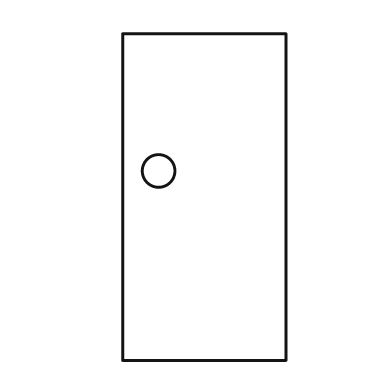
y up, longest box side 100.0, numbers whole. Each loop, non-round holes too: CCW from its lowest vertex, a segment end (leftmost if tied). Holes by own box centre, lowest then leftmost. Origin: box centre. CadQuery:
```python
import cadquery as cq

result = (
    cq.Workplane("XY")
    .moveTo(-25.0, -50.0)
    .lineTo(25.0, -50.0)
    .lineTo(25.0, 50.0)
    .lineTo(-25.0, 50.0)
    .close()
    .moveTo(-14.0, 8.0)
    .circle(5.0)
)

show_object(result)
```